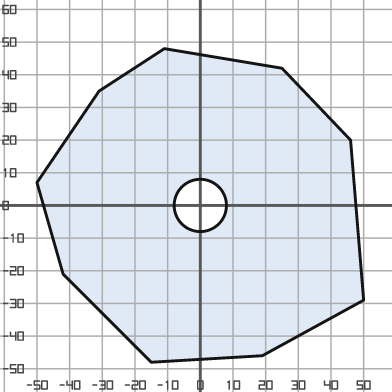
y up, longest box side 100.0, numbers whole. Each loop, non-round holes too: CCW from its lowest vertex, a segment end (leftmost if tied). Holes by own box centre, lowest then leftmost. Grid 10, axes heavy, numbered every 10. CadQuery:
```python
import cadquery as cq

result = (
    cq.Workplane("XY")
    .moveTo(-15.0, -48.0)
    .lineTo(19.0, -46.0)
    .lineTo(50.0, -29.0)
    .lineTo(46.0, 20.0)
    .lineTo(25.0, 42.0)
    .lineTo(-11.0, 48.0)
    .lineTo(-31.0, 35.0)
    .lineTo(-50.0, 7.0)
    .lineTo(-42.0, -21.0)
    .close()
    .moveTo(0.0, 0.0)
    .circle(8.0)
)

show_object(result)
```